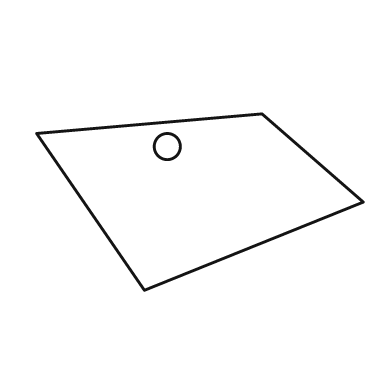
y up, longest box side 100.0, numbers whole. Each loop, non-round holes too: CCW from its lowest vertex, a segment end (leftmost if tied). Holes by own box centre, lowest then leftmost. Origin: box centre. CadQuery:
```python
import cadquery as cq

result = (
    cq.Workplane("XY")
    .moveTo(-17.0, -27.0)
    .lineTo(50.0, 0.0)
    .lineTo(19.0, 27.0)
    .lineTo(-50.0, 21.0)
    .close()
    .moveTo(-10.0, 17.0)
    .circle(4.0)
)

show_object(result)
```